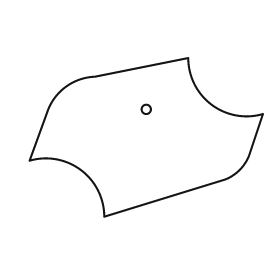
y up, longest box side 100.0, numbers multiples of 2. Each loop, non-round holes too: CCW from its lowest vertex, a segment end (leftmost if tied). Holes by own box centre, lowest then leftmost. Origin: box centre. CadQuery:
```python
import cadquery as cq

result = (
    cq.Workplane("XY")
    .moveTo(-18.0, -34.0)
    .lineTo(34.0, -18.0)
    .threePointArc((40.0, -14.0), (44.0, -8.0))
    .lineTo(50.0, 10.0)
    .threePointArc((28.0, 14.0), (18.0, 34.0))
    .lineTo(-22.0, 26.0)
    .threePointArc((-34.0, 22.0), (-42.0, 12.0))
    .lineTo(-50.0, -10.0)
    .threePointArc((-28.0, -14.0), (-18.0, -34.0))
    .close()
    .moveTo(0.0, 12.0)
    .circle(2.0)
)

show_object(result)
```